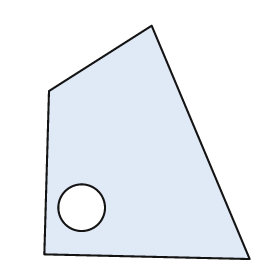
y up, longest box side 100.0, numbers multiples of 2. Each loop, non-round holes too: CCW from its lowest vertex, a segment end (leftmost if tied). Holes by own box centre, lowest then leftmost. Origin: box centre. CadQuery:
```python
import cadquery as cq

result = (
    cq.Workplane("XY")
    .moveTo(44.0, -50.0)
    .lineTo(2.0, 50.0)
    .lineTo(-42.0, 22.0)
    .lineTo(-44.0, -48.0)
    .close()
    .moveTo(-28.0, -28.0)
    .circle(10.0)
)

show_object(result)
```